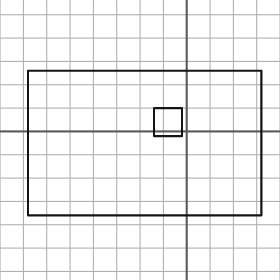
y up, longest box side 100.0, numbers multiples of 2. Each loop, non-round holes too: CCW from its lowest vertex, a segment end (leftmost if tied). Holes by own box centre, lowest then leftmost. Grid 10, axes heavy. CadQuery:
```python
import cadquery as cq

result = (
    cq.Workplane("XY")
    .moveTo(-68.0, -36.0)
    .lineTo(32.0, -36.0)
    .lineTo(32.0, 26.0)
    .lineTo(-68.0, 26.0)
    .close()
    .moveTo(-14.0, -2.0)
    .lineTo(-2.0, -2.0)
    .lineTo(-2.0, 10.0)
    .lineTo(-14.0, 10.0)
    .close()
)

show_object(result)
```